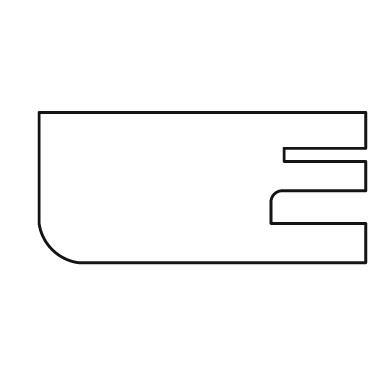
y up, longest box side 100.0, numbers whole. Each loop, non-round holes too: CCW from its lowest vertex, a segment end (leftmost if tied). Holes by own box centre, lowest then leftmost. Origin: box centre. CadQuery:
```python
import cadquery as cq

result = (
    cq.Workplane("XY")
    .moveTo(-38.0, -23.0)
    .lineTo(50.0, -23.0)
    .lineTo(50.0, -11.0)
    .lineTo(21.0, -11.0)
    .lineTo(21.0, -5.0)
    .threePointArc((22.0, -2.0), (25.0, -1.0))
    .lineTo(50.0, -1.0)
    .lineTo(50.0, 8.0)
    .lineTo(25.0, 8.0)
    .lineTo(25.0, 12.0)
    .lineTo(50.0, 12.0)
    .lineTo(50.0, 23.0)
    .lineTo(-50.0, 23.0)
    .lineTo(-50.0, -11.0)
    .threePointArc((-46.0, -19.0), (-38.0, -23.0))
    .close()
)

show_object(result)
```